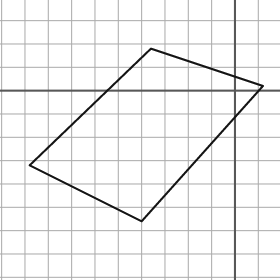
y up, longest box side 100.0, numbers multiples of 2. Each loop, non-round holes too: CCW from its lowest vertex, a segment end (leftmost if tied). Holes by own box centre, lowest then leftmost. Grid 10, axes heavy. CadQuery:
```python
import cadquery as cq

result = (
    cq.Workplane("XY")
    .moveTo(-40.0, -56.0)
    .lineTo(12.0, 2.0)
    .lineTo(-36.0, 18.0)
    .lineTo(-88.0, -32.0)
    .close()
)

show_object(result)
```